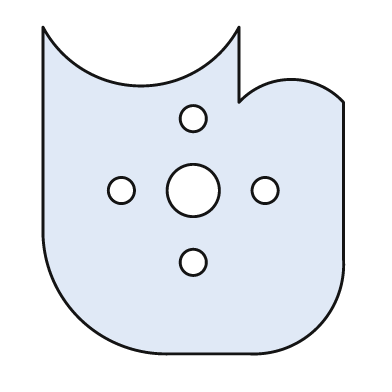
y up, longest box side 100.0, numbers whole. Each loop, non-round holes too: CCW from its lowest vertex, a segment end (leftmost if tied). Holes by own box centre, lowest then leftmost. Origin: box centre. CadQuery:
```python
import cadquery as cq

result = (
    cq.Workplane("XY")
    .moveTo(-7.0, -50.0)
    .lineTo(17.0, -50.0)
    .threePointArc((38.0, -42.0), (46.0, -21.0))
    .lineTo(46.0, 27.0)
    .threePointArc((30.0, 34.0), (14.0, 27.0))
    .lineTo(14.0, 50.0)
    .threePointArc((-16.0, 32.0), (-46.0, 50.0))
    .lineTo(-46.0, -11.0)
    .threePointArc((-35.0, -39.0), (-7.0, -50.0))
    .close()
    .moveTo(0.0, -22.0)
    .circle(4.0)
    .moveTo(-22.0, 0.0)
    .circle(4.0)
    .moveTo(0.0, 0.0)
    .circle(8.0)
    .moveTo(22.0, 0.0)
    .circle(4.0)
    .moveTo(0.0, 22.0)
    .circle(4.0)
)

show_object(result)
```